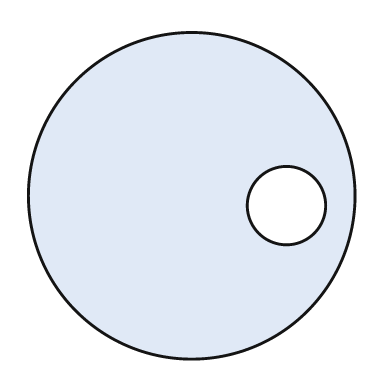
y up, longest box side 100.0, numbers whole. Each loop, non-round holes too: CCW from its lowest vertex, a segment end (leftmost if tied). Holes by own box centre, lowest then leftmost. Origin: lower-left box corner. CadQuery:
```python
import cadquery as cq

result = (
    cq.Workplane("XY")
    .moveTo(50.0, 50.0)
    .circle(50.0)
    .moveTo(79.0, 47.0)
    .circle(12.0)
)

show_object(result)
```